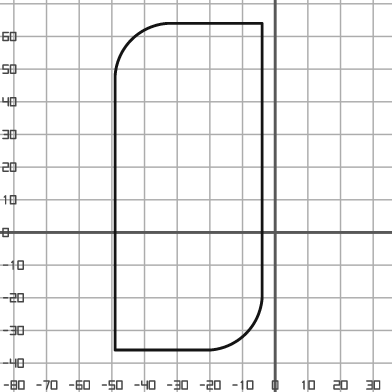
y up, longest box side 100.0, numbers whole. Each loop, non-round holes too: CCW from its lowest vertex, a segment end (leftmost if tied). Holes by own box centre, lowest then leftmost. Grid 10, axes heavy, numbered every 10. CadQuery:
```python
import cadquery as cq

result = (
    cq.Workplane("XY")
    .moveTo(-49.0, -36.0)
    .lineTo(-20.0, -36.0)
    .threePointArc((-9.0, -31.0), (-4.0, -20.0))
    .lineTo(-4.0, 64.0)
    .lineTo(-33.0, 64.0)
    .threePointArc((-44.0, 59.0), (-49.0, 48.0))
    .close()
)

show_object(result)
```